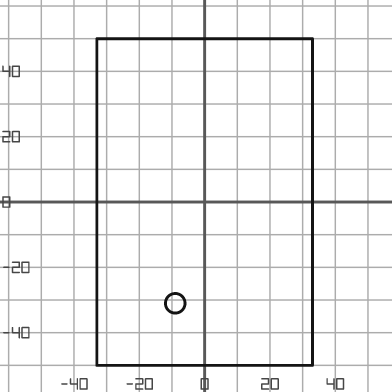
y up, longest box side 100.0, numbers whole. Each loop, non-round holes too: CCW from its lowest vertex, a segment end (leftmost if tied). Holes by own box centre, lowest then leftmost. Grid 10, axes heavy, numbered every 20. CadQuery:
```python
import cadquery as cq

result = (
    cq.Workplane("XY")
    .moveTo(-33.0, -50.0)
    .lineTo(33.0, -50.0)
    .lineTo(33.0, 50.0)
    .lineTo(-33.0, 50.0)
    .close()
    .moveTo(-9.0, -31.0)
    .circle(3.0)
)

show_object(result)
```